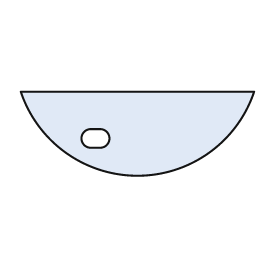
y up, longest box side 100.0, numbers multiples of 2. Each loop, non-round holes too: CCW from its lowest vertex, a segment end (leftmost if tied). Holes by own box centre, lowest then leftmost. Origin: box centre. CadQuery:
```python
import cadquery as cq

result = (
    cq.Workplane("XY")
    .moveTo(-50.0, 18.0)
    .threePointArc((0.0, -18.0), (50.0, 18.0))
    .close()
    .moveTo(-20.0, -6.0)
    .lineTo(-16.0, -6.0)
    .threePointArc((-12.0, -2.0), (-16.0, 2.0))
    .lineTo(-20.0, 2.0)
    .threePointArc((-24.0, -2.0), (-20.0, -6.0))
    .close()
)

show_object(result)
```